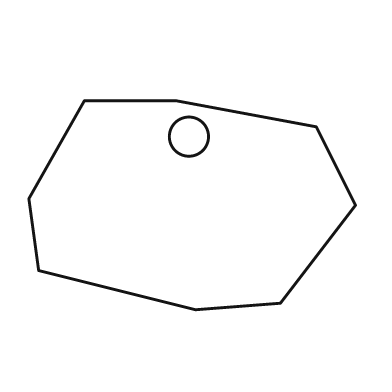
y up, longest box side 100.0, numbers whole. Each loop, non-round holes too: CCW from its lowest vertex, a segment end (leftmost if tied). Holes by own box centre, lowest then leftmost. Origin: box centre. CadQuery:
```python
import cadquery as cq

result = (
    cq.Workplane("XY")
    .moveTo(1.0, -32.0)
    .lineTo(27.0, -30.0)
    .lineTo(50.0, 0.0)
    .lineTo(38.0, 24.0)
    .lineTo(-5.0, 32.0)
    .lineTo(-33.0, 32.0)
    .lineTo(-50.0, 2.0)
    .lineTo(-47.0, -20.0)
    .close()
    .moveTo(-1.0, 21.0)
    .circle(6.0)
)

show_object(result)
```